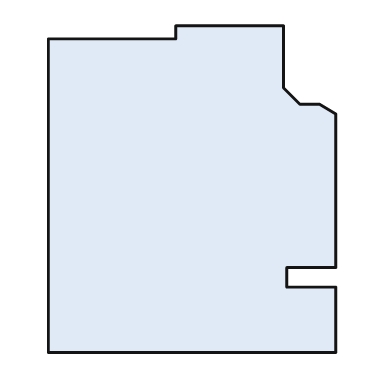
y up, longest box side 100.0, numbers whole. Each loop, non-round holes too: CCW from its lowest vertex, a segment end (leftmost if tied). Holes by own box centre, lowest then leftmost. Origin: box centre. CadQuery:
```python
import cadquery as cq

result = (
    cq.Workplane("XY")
    .moveTo(-44.0, -50.0)
    .lineTo(44.0, -50.0)
    .lineTo(44.0, -30.0)
    .lineTo(29.0, -30.0)
    .lineTo(29.0, -24.0)
    .lineTo(44.0, -24.0)
    .lineTo(44.0, 23.0)
    .lineTo(39.0, 26.0)
    .lineTo(33.0, 26.0)
    .lineTo(28.0, 31.0)
    .lineTo(28.0, 50.0)
    .lineTo(-5.0, 50.0)
    .lineTo(-5.0, 46.0)
    .lineTo(-44.0, 46.0)
    .close()
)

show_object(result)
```